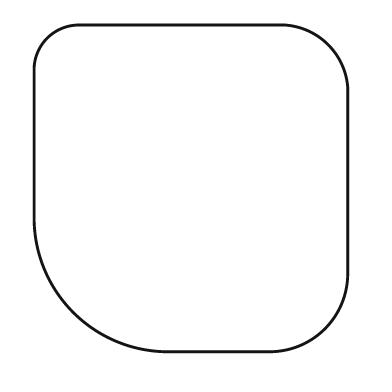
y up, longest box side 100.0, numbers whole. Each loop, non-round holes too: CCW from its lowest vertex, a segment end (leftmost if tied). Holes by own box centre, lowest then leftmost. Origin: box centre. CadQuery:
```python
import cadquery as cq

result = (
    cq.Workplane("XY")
    .moveTo(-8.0, -50.0)
    .lineTo(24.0, -50.0)
    .threePointArc((41.0, -43.0), (48.0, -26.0))
    .lineTo(48.0, 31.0)
    .threePointArc((42.0, 44.0), (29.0, 50.0))
    .lineTo(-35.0, 50.0)
    .threePointArc((-44.0, 46.0), (-48.0, 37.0))
    .lineTo(-48.0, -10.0)
    .threePointArc((-36.0, -38.0), (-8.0, -50.0))
    .close()
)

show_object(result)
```